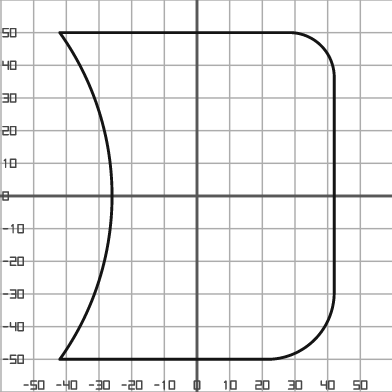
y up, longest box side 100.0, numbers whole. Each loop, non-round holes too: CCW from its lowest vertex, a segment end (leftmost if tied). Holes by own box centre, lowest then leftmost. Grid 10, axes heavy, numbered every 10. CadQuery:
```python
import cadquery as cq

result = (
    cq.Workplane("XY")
    .moveTo(-42.0, -50.0)
    .lineTo(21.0, -50.0)
    .threePointArc((36.0, -44.0), (42.0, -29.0))
    .lineTo(42.0, 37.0)
    .threePointArc((38.0, 46.0), (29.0, 50.0))
    .lineTo(-42.0, 50.0)
    .threePointArc((-26.0, 0.0), (-42.0, -50.0))
    .close()
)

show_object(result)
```